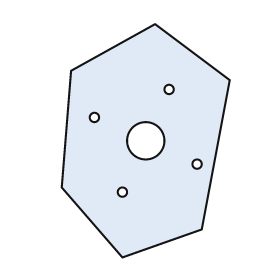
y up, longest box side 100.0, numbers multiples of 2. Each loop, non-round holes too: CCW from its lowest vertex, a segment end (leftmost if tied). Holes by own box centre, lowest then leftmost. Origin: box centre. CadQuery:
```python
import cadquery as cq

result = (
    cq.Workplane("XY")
    .moveTo(-10.0, -50.0)
    .lineTo(24.0, -38.0)
    .lineTo(36.0, 26.0)
    .lineTo(4.0, 50.0)
    .lineTo(-32.0, 30.0)
    .lineTo(-36.0, -20.0)
    .close()
    .moveTo(-10.0, -22.0)
    .circle(2.0)
    .moveTo(22.0, -10.0)
    .circle(2.0)
    .moveTo(0.0, 0.0)
    .circle(8.0)
    .moveTo(-22.0, 10.0)
    .circle(2.0)
    .moveTo(10.0, 22.0)
    .circle(2.0)
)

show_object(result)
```